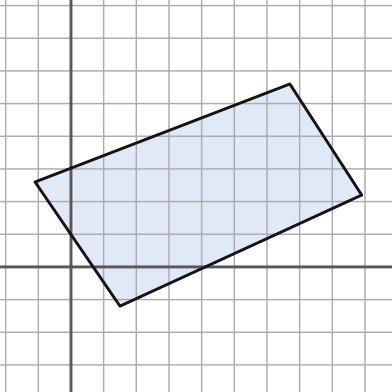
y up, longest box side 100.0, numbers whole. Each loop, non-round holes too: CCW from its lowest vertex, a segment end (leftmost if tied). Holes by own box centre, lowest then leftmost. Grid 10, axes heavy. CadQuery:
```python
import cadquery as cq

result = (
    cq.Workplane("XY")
    .moveTo(15.0, -12.0)
    .lineTo(89.0, 22.0)
    .lineTo(67.0, 56.0)
    .lineTo(-11.0, 26.0)
    .close()
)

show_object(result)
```